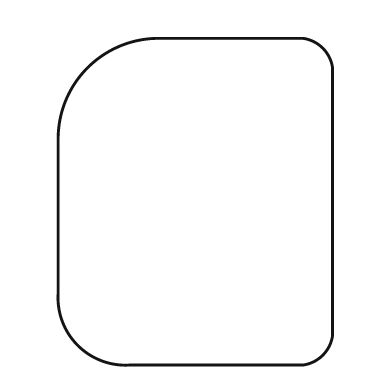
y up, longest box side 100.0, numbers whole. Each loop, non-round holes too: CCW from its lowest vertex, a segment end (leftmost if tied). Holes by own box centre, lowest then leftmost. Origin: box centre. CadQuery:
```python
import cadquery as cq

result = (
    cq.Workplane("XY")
    .moveTo(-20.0, -50.0)
    .lineTo(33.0, -50.0)
    .threePointArc((39.0, -47.0), (42.0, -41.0))
    .lineTo(42.0, 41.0)
    .threePointArc((39.0, 47.0), (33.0, 50.0))
    .lineTo(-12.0, 50.0)
    .threePointArc((-33.0, 41.0), (-42.0, 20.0))
    .lineTo(-42.0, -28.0)
    .threePointArc((-36.0, -44.0), (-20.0, -50.0))
    .close()
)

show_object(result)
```